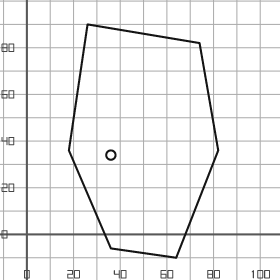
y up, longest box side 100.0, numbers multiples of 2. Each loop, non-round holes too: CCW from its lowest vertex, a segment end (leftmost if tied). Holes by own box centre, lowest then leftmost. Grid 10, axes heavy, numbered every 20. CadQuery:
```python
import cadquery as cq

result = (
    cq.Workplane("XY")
    .moveTo(64.0, -10.0)
    .lineTo(82.0, 36.0)
    .lineTo(74.0, 82.0)
    .lineTo(26.0, 90.0)
    .lineTo(18.0, 36.0)
    .lineTo(36.0, -6.0)
    .close()
    .moveTo(36.0, 34.0)
    .circle(2.0)
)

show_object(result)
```